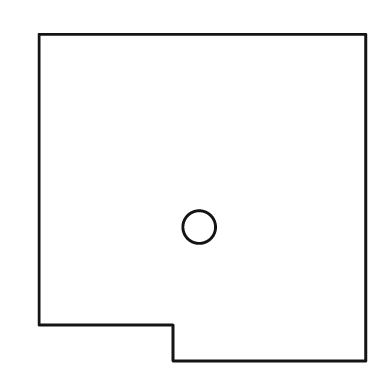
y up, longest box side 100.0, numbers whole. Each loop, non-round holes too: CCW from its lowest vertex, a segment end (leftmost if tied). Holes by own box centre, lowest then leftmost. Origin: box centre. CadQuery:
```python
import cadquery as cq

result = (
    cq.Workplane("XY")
    .moveTo(-9.0, -50.0)
    .lineTo(50.0, -50.0)
    .lineTo(50.0, 50.0)
    .lineTo(-50.0, 50.0)
    .lineTo(-50.0, -39.0)
    .lineTo(-9.0, -39.0)
    .close()
    .moveTo(-1.0, -9.0)
    .circle(5.0)
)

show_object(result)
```